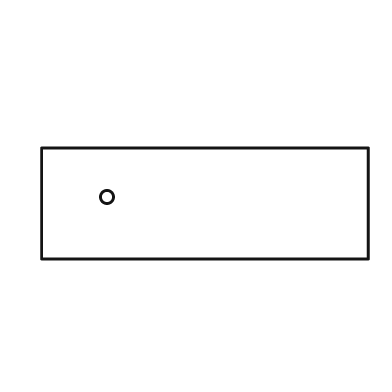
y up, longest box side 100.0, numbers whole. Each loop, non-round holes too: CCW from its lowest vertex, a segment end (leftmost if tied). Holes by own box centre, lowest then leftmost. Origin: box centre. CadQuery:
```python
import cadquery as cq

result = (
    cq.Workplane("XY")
    .moveTo(-50.0, -17.0)
    .lineTo(50.0, -17.0)
    .lineTo(50.0, 17.0)
    .lineTo(-50.0, 17.0)
    .close()
    .moveTo(-30.0, 2.0)
    .circle(2.0)
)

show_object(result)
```